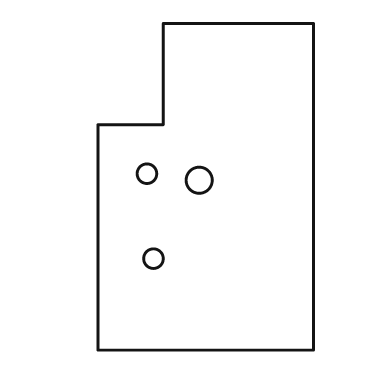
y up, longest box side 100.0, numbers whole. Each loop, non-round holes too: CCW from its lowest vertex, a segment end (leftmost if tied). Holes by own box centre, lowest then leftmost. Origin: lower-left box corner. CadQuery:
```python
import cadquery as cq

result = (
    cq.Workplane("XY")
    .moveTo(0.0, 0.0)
    .lineTo(66.0, 0.0)
    .lineTo(66.0, 100.0)
    .lineTo(20.0, 100.0)
    .lineTo(20.0, 69.0)
    .lineTo(0.0, 69.0)
    .close()
    .moveTo(17.0, 28.0)
    .circle(3.0)
    .moveTo(31.0, 52.0)
    .circle(4.0)
    .moveTo(15.0, 54.0)
    .circle(3.0)
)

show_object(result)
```